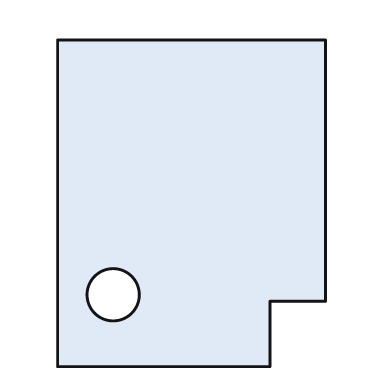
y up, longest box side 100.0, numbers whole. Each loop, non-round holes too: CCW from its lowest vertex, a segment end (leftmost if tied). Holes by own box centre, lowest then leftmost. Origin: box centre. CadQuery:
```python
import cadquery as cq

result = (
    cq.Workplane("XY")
    .moveTo(-41.0, -50.0)
    .lineTo(24.0, -50.0)
    .lineTo(24.0, -30.0)
    .lineTo(41.0, -30.0)
    .lineTo(41.0, 50.0)
    .lineTo(-41.0, 50.0)
    .close()
    .moveTo(-24.0, -28.0)
    .circle(8.0)
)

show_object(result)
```